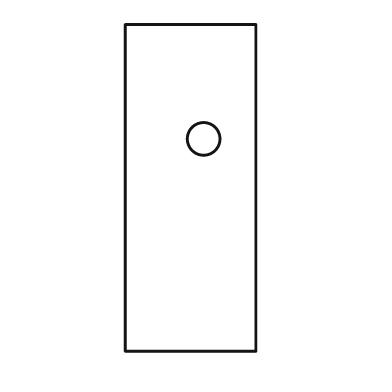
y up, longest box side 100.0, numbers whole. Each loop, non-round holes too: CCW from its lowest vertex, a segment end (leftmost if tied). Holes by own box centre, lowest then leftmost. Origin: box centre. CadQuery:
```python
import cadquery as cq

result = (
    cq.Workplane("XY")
    .moveTo(-20.0, -50.0)
    .lineTo(20.0, -50.0)
    .lineTo(20.0, 50.0)
    .lineTo(-20.0, 50.0)
    .close()
    .moveTo(4.0, 15.0)
    .circle(5.0)
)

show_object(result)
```